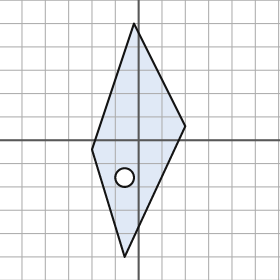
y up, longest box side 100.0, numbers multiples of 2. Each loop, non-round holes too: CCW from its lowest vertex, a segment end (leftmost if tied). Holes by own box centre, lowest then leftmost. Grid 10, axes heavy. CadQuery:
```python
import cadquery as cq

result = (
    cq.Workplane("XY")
    .moveTo(-6.0, -50.0)
    .lineTo(20.0, 6.0)
    .lineTo(-2.0, 50.0)
    .lineTo(-20.0, -4.0)
    .close()
    .moveTo(-6.0, -16.0)
    .circle(4.0)
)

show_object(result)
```